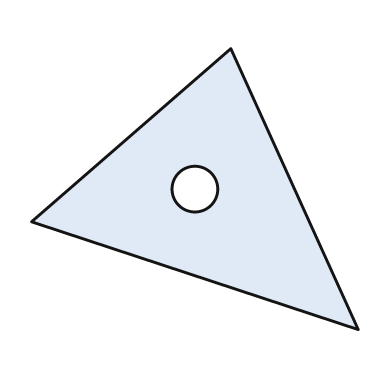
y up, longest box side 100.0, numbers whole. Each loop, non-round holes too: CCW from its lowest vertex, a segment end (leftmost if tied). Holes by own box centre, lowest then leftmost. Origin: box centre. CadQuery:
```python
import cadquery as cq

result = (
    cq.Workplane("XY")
    .moveTo(50.0, -43.0)
    .lineTo(11.0, 43.0)
    .lineTo(-50.0, -10.0)
    .close()
    .moveTo(0.0, 0.0)
    .circle(7.0)
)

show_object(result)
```